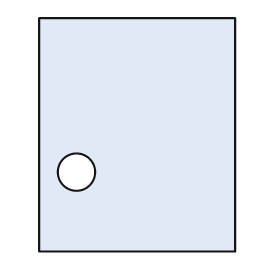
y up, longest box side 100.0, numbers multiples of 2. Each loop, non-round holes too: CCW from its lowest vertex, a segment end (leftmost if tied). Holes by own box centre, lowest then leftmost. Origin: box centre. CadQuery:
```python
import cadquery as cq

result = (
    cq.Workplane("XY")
    .moveTo(-42.0, -50.0)
    .lineTo(42.0, -50.0)
    .lineTo(42.0, 50.0)
    .lineTo(-42.0, 50.0)
    .close()
    .moveTo(-26.0, -16.0)
    .circle(8.0)
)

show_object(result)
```